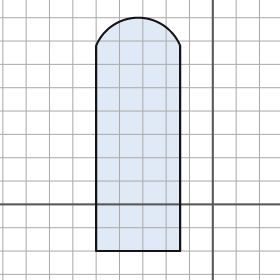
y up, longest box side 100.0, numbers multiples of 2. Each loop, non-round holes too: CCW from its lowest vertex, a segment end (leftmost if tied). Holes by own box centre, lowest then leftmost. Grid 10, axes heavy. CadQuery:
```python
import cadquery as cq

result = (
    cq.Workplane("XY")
    .moveTo(-50.0, -20.0)
    .lineTo(-14.0, -20.0)
    .lineTo(-14.0, 68.0)
    .threePointArc((-32.0, 80.0), (-50.0, 68.0))
    .close()
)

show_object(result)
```